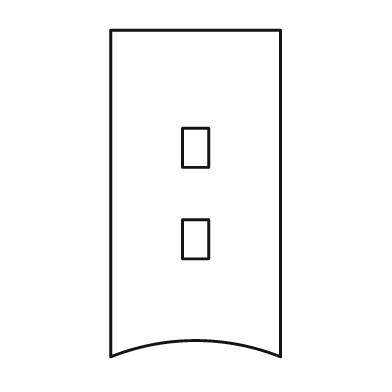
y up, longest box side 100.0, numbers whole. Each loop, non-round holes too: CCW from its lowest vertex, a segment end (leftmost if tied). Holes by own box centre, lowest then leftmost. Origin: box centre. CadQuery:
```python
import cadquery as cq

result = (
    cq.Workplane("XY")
    .moveTo(-26.0, -50.0)
    .threePointArc((0.0, -45.0), (26.0, -50.0))
    .lineTo(26.0, 50.0)
    .lineTo(-26.0, 50.0)
    .close()
    .moveTo(-4.0, -20.0)
    .lineTo(4.0, -20.0)
    .lineTo(4.0, -8.0)
    .lineTo(-4.0, -8.0)
    .close()
    .moveTo(-4.0, 8.0)
    .lineTo(4.0, 8.0)
    .lineTo(4.0, 20.0)
    .lineTo(-4.0, 20.0)
    .close()
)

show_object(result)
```